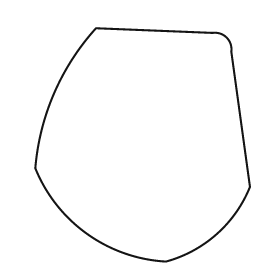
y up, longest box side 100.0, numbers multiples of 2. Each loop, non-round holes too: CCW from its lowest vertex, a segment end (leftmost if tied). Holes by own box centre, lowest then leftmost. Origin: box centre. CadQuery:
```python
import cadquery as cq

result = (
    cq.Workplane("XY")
    .moveTo(10.0, -50.0)
    .threePointArc((32.0, -38.0), (46.0, -18.0))
    .lineTo(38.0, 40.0)
    .threePointArc((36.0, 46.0), (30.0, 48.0))
    .lineTo(-20.0, 50.0)
    .threePointArc((-38.0, 22.0), (-46.0, -10.0))
    .threePointArc((-24.0, -38.0), (10.0, -50.0))
    .close()
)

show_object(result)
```